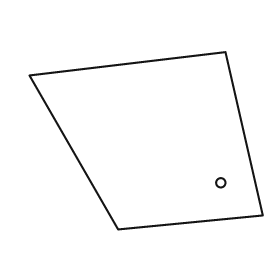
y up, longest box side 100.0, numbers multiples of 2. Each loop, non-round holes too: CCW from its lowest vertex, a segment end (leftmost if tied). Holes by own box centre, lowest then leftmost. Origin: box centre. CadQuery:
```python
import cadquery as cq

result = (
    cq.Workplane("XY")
    .moveTo(-12.0, -38.0)
    .lineTo(50.0, -32.0)
    .lineTo(34.0, 38.0)
    .lineTo(-50.0, 28.0)
    .close()
    .moveTo(32.0, -18.0)
    .circle(2.0)
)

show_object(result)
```